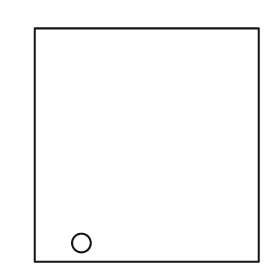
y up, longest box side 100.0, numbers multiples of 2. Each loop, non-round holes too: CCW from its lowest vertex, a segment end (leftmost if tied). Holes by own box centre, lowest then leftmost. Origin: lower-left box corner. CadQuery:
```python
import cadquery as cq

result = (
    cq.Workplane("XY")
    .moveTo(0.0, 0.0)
    .lineTo(96.0, 0.0)
    .lineTo(96.0, 100.0)
    .lineTo(0.0, 100.0)
    .close()
    .moveTo(20.0, 8.0)
    .circle(4.0)
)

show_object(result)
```